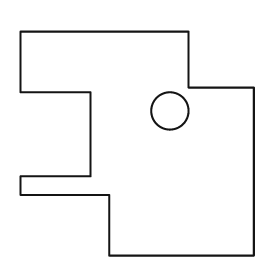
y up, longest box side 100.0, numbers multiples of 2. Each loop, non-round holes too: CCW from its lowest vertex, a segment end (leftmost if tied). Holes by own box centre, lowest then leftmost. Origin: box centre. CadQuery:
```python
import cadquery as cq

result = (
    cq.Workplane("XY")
    .moveTo(-12.0, -48.0)
    .lineTo(50.0, -48.0)
    .lineTo(50.0, 24.0)
    .lineTo(22.0, 24.0)
    .lineTo(22.0, 48.0)
    .lineTo(-50.0, 48.0)
    .lineTo(-50.0, 22.0)
    .lineTo(-20.0, 22.0)
    .lineTo(-20.0, -14.0)
    .lineTo(-50.0, -14.0)
    .lineTo(-50.0, -22.0)
    .lineTo(-12.0, -22.0)
    .close()
    .moveTo(14.0, 14.0)
    .circle(8.0)
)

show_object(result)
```